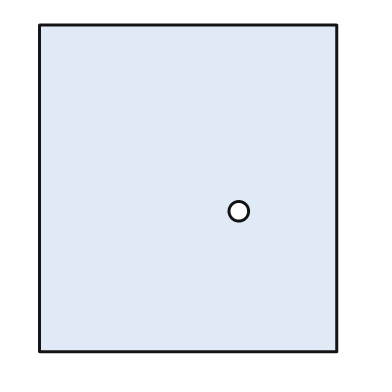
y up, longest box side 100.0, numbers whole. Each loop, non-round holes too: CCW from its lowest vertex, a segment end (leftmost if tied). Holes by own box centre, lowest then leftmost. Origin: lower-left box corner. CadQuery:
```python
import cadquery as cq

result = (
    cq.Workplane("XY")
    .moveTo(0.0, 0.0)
    .lineTo(91.0, 0.0)
    .lineTo(91.0, 100.0)
    .lineTo(0.0, 100.0)
    .close()
    .moveTo(61.0, 43.0)
    .circle(3.0)
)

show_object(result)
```